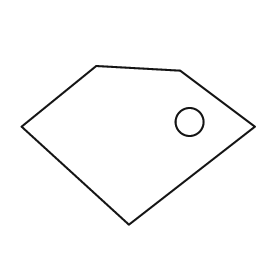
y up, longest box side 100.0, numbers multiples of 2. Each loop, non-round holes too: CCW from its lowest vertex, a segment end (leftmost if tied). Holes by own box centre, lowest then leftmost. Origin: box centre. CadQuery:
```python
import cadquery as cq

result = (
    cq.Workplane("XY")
    .moveTo(-4.0, -34.0)
    .lineTo(50.0, 8.0)
    .lineTo(18.0, 32.0)
    .lineTo(-18.0, 34.0)
    .lineTo(-50.0, 8.0)
    .close()
    .moveTo(22.0, 10.0)
    .circle(6.0)
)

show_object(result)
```